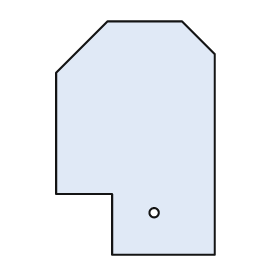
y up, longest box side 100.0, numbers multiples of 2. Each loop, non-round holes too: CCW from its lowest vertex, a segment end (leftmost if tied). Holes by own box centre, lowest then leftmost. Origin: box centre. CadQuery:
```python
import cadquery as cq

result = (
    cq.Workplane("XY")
    .moveTo(-10.0, -50.0)
    .lineTo(34.0, -50.0)
    .lineTo(34.0, 36.0)
    .lineTo(20.0, 50.0)
    .lineTo(-12.0, 50.0)
    .lineTo(-34.0, 28.0)
    .lineTo(-34.0, -24.0)
    .lineTo(-10.0, -24.0)
    .close()
    .moveTo(8.0, -32.0)
    .circle(2.0)
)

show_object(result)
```